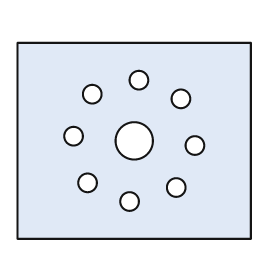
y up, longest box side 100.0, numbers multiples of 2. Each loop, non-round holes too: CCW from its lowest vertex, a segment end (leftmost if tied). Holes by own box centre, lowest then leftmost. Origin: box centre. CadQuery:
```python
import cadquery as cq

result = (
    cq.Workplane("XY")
    .moveTo(-50.0, -42.0)
    .lineTo(50.0, -42.0)
    .lineTo(50.0, 42.0)
    .lineTo(-50.0, 42.0)
    .close()
    .moveTo(-2.0, -26.0)
    .circle(4.0)
    .moveTo(18.0, -20.0)
    .circle(4.0)
    .moveTo(-20.0, -18.0)
    .circle(4.0)
    .moveTo(26.0, -2.0)
    .circle(4.0)
    .moveTo(0.0, 0.0)
    .circle(8.0)
    .moveTo(-26.0, 2.0)
    .circle(4.0)
    .moveTo(20.0, 18.0)
    .circle(4.0)
    .moveTo(-18.0, 20.0)
    .circle(4.0)
    .moveTo(2.0, 26.0)
    .circle(4.0)
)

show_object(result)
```